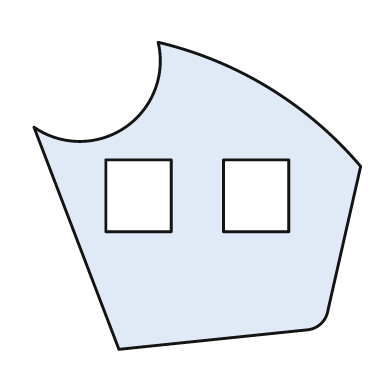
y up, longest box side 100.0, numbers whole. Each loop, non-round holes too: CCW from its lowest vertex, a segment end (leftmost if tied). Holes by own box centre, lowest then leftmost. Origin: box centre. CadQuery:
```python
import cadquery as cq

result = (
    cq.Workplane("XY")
    .moveTo(-24.0, -47.0)
    .lineTo(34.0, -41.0)
    .threePointArc((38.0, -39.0), (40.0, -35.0))
    .lineTo(50.0, 9.0)
    .threePointArc((22.0, 33.0), (-12.0, 47.0))
    .threePointArc((-22.0, 21.0), (-50.0, 21.0))
    .close()
    .moveTo(-28.0, -11.0)
    .lineTo(-8.0, -11.0)
    .lineTo(-8.0, 11.0)
    .lineTo(-28.0, 11.0)
    .close()
    .moveTo(8.0, -11.0)
    .lineTo(28.0, -11.0)
    .lineTo(28.0, 11.0)
    .lineTo(8.0, 11.0)
    .close()
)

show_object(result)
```